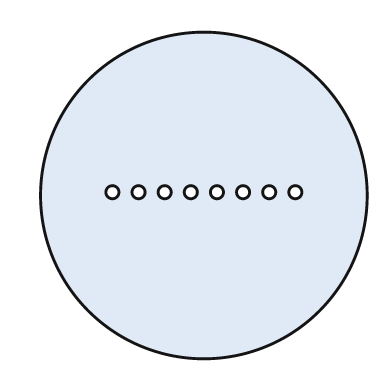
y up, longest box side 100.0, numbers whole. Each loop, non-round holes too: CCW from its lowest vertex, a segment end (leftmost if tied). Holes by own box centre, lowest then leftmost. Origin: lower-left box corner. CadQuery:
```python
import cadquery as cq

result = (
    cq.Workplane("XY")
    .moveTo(50.0, 50.0)
    .circle(50.0)
    .moveTo(22.0, 51.0)
    .circle(2.0)
    .moveTo(30.0, 51.0)
    .circle(2.0)
    .moveTo(38.0, 51.0)
    .circle(2.0)
    .moveTo(46.0, 51.0)
    .circle(2.0)
    .moveTo(54.0, 51.0)
    .circle(2.0)
    .moveTo(62.0, 51.0)
    .circle(2.0)
    .moveTo(70.0, 51.0)
    .circle(2.0)
    .moveTo(78.0, 51.0)
    .circle(2.0)
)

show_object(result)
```